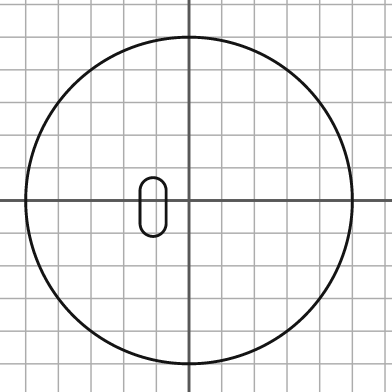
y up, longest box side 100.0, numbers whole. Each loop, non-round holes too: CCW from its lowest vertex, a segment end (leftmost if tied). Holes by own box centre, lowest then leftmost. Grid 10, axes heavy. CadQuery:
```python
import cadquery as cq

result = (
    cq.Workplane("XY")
    .moveTo(0.0, 0.0)
    .circle(50.0)
    .moveTo(-15.0, -7.0)
    .threePointArc((-11.0, -11.0), (-7.0, -7.0))
    .lineTo(-7.0, 3.0)
    .threePointArc((-11.0, 7.0), (-15.0, 3.0))
    .close()
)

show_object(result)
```